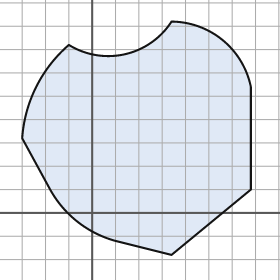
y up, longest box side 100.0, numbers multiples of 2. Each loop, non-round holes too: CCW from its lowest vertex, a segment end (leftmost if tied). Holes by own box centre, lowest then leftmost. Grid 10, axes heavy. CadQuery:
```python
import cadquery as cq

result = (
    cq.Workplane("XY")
    .moveTo(34.0, -18.0)
    .lineTo(68.0, 10.0)
    .lineTo(68.0, 54.0)
    .threePointArc((56.0, 74.0), (34.0, 82.0))
    .threePointArc((14.0, 68.0), (-10.0, 72.0))
    .threePointArc((-24.0, 54.0), (-30.0, 32.0))
    .lineTo(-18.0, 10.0)
    .threePointArc((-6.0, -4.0), (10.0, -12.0))
    .close()
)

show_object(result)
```